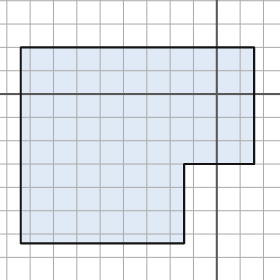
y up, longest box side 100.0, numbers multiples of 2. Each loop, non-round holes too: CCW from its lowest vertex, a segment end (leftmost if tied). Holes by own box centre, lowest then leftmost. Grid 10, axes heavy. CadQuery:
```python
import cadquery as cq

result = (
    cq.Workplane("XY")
    .moveTo(-84.0, -64.0)
    .lineTo(-14.0, -64.0)
    .lineTo(-14.0, -30.0)
    .lineTo(16.0, -30.0)
    .lineTo(16.0, 20.0)
    .lineTo(-84.0, 20.0)
    .close()
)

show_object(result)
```